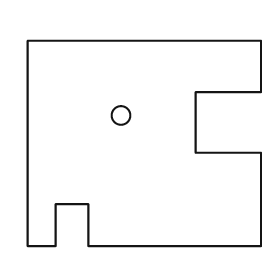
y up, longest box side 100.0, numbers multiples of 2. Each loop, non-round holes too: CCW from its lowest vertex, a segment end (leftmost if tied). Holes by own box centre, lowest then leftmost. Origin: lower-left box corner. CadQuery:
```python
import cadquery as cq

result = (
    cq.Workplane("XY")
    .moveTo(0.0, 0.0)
    .lineTo(12.0, 0.0)
    .lineTo(12.0, 18.0)
    .lineTo(26.0, 18.0)
    .lineTo(26.0, 0.0)
    .lineTo(100.0, 0.0)
    .lineTo(100.0, 40.0)
    .lineTo(72.0, 40.0)
    .lineTo(72.0, 66.0)
    .lineTo(100.0, 66.0)
    .lineTo(100.0, 88.0)
    .lineTo(0.0, 88.0)
    .close()
    .moveTo(40.0, 56.0)
    .circle(4.0)
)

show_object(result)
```